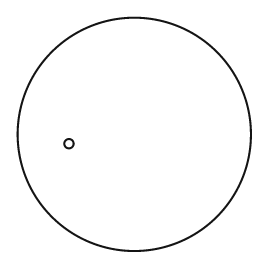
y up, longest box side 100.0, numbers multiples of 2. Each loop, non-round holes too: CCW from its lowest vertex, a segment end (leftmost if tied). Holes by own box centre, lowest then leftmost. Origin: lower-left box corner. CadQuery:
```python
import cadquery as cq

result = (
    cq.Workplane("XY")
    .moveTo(50.0, 50.0)
    .circle(50.0)
    .moveTo(22.0, 46.0)
    .circle(2.0)
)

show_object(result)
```